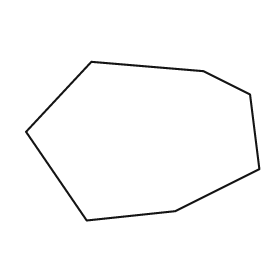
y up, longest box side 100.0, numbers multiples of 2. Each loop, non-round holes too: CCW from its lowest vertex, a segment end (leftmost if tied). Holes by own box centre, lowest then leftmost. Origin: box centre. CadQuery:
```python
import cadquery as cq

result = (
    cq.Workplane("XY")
    .moveTo(-24.0, -34.0)
    .lineTo(14.0, -30.0)
    .lineTo(50.0, -12.0)
    .lineTo(46.0, 20.0)
    .lineTo(26.0, 30.0)
    .lineTo(-22.0, 34.0)
    .lineTo(-50.0, 4.0)
    .close()
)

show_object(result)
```